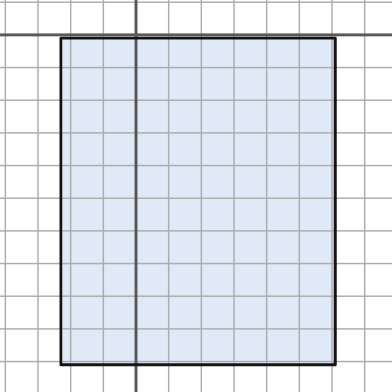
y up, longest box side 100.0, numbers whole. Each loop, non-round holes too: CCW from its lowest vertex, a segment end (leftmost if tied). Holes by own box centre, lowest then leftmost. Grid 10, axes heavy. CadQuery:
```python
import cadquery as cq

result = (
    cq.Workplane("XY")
    .moveTo(-23.0, -101.0)
    .lineTo(61.0, -101.0)
    .lineTo(61.0, -1.0)
    .lineTo(-23.0, -1.0)
    .close()
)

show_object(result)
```